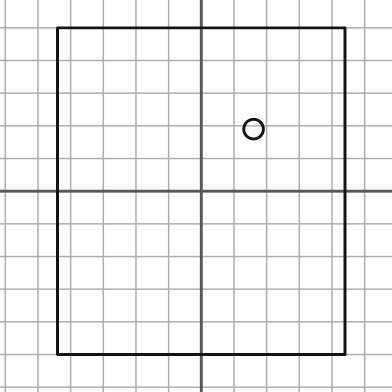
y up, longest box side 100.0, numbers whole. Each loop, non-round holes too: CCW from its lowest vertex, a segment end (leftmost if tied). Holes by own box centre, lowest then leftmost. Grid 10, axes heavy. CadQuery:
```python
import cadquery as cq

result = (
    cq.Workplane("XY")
    .moveTo(-44.0, -50.0)
    .lineTo(44.0, -50.0)
    .lineTo(44.0, 50.0)
    .lineTo(-44.0, 50.0)
    .close()
    .moveTo(16.0, 19.0)
    .circle(3.0)
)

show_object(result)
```